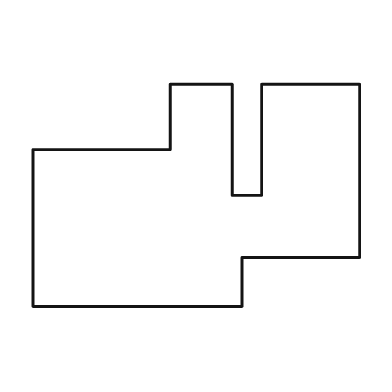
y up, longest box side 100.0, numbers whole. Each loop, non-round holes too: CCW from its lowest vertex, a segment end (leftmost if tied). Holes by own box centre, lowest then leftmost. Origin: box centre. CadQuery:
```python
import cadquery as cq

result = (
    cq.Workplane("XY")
    .moveTo(-50.0, -34.0)
    .lineTo(14.0, -34.0)
    .lineTo(14.0, -19.0)
    .lineTo(50.0, -19.0)
    .lineTo(50.0, 34.0)
    .lineTo(20.0, 34.0)
    .lineTo(20.0, 0.0)
    .lineTo(11.0, 0.0)
    .lineTo(11.0, 34.0)
    .lineTo(-8.0, 34.0)
    .lineTo(-8.0, 14.0)
    .lineTo(-50.0, 14.0)
    .close()
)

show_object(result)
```